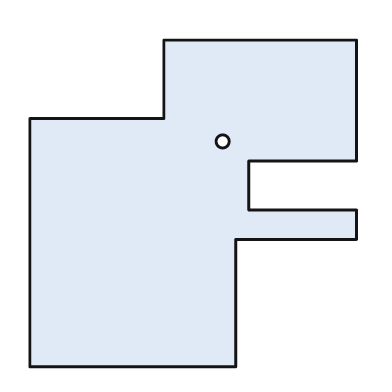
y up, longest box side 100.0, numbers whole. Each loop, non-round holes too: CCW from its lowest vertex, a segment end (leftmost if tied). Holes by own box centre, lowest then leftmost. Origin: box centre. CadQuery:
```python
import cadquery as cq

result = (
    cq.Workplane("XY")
    .moveTo(-50.0, -50.0)
    .lineTo(13.0, -50.0)
    .lineTo(13.0, -11.0)
    .lineTo(50.0, -11.0)
    .lineTo(50.0, -2.0)
    .lineTo(17.0, -2.0)
    .lineTo(17.0, 13.0)
    .lineTo(50.0, 13.0)
    .lineTo(50.0, 50.0)
    .lineTo(-9.0, 50.0)
    .lineTo(-9.0, 26.0)
    .lineTo(-50.0, 26.0)
    .close()
    .moveTo(9.0, 19.0)
    .circle(2.0)
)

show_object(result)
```